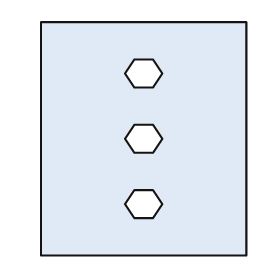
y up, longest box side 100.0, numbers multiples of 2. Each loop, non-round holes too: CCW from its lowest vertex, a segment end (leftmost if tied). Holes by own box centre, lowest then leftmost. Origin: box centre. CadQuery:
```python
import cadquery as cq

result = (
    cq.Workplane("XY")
    .moveTo(-44.0, -50.0)
    .lineTo(44.0, -50.0)
    .lineTo(44.0, 50.0)
    .lineTo(-44.0, 50.0)
    .close()
    .moveTo(-4.0, -34.0)
    .lineTo(4.0, -34.0)
    .lineTo(8.0, -28.0)
    .lineTo(4.0, -22.0)
    .lineTo(-4.0, -22.0)
    .lineTo(-8.0, -28.0)
    .close()
    .moveTo(-4.0, -6.0)
    .lineTo(4.0, -6.0)
    .lineTo(8.0, 0.0)
    .lineTo(4.0, 6.0)
    .lineTo(-4.0, 6.0)
    .lineTo(-8.0, 0.0)
    .close()
    .moveTo(-4.0, 22.0)
    .lineTo(4.0, 22.0)
    .lineTo(8.0, 28.0)
    .lineTo(4.0, 34.0)
    .lineTo(-4.0, 34.0)
    .lineTo(-8.0, 28.0)
    .close()
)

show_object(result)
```